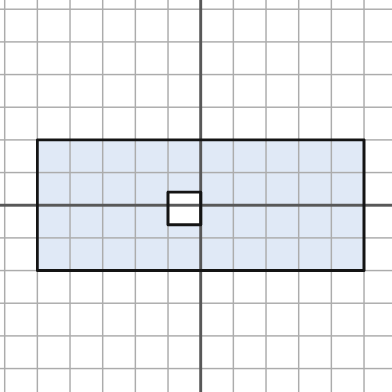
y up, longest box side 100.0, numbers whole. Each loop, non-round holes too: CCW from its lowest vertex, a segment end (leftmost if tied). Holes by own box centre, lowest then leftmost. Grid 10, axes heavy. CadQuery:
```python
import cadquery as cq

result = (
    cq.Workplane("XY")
    .moveTo(-50.0, -20.0)
    .lineTo(50.0, -20.0)
    .lineTo(50.0, 20.0)
    .lineTo(-50.0, 20.0)
    .close()
    .moveTo(-10.0, -6.0)
    .lineTo(0.0, -6.0)
    .lineTo(0.0, 4.0)
    .lineTo(-10.0, 4.0)
    .close()
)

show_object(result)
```